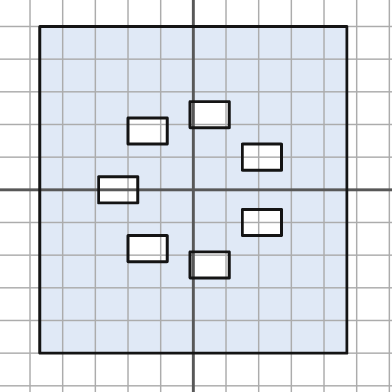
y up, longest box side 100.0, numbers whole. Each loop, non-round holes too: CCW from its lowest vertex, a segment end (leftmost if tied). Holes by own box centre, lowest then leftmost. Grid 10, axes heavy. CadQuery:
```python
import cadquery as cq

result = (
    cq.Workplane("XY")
    .moveTo(-47.0, -50.0)
    .lineTo(47.0, -50.0)
    .lineTo(47.0, 50.0)
    .lineTo(-47.0, 50.0)
    .close()
    .moveTo(-1.0, -27.0)
    .lineTo(11.0, -27.0)
    .lineTo(11.0, -19.0)
    .lineTo(-1.0, -19.0)
    .close()
    .moveTo(-20.0, -22.0)
    .lineTo(-8.0, -22.0)
    .lineTo(-8.0, -14.0)
    .lineTo(-20.0, -14.0)
    .close()
    .moveTo(15.0, -14.0)
    .lineTo(27.0, -14.0)
    .lineTo(27.0, -6.0)
    .lineTo(15.0, -6.0)
    .close()
    .moveTo(-29.0, -4.0)
    .lineTo(-17.0, -4.0)
    .lineTo(-17.0, 4.0)
    .lineTo(-29.0, 4.0)
    .close()
    .moveTo(15.0, 6.0)
    .lineTo(27.0, 6.0)
    .lineTo(27.0, 14.0)
    .lineTo(15.0, 14.0)
    .close()
    .moveTo(-20.0, 14.0)
    .lineTo(-8.0, 14.0)
    .lineTo(-8.0, 22.0)
    .lineTo(-20.0, 22.0)
    .close()
    .moveTo(-1.0, 19.0)
    .lineTo(11.0, 19.0)
    .lineTo(11.0, 27.0)
    .lineTo(-1.0, 27.0)
    .close()
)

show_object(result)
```